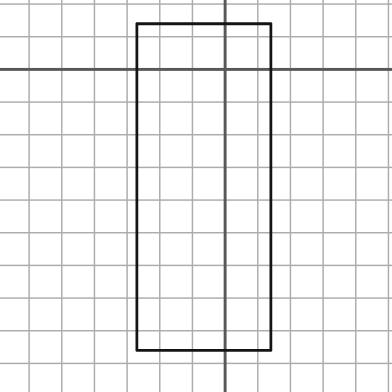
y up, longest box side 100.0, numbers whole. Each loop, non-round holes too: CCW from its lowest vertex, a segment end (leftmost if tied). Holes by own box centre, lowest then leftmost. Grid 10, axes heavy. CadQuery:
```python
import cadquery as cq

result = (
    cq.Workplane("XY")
    .moveTo(-27.0, -86.0)
    .lineTo(14.0, -86.0)
    .lineTo(14.0, 14.0)
    .lineTo(-27.0, 14.0)
    .close()
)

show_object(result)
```